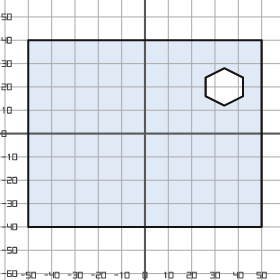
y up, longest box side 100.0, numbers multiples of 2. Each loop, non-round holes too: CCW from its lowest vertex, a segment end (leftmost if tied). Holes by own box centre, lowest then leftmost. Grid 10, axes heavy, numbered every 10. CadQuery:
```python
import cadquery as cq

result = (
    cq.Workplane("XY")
    .moveTo(-50.0, -40.0)
    .lineTo(50.0, -40.0)
    .lineTo(50.0, 40.0)
    .lineTo(-50.0, 40.0)
    .close()
    .moveTo(34.0, 12.0)
    .lineTo(42.0, 16.0)
    .lineTo(42.0, 24.0)
    .lineTo(34.0, 28.0)
    .lineTo(26.0, 24.0)
    .lineTo(26.0, 16.0)
    .close()
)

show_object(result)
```